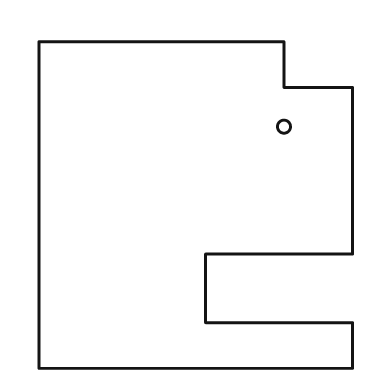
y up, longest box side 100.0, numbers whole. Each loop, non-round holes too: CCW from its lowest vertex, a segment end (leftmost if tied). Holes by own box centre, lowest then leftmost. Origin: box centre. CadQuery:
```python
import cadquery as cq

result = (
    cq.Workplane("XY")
    .moveTo(-48.0, -50.0)
    .lineTo(48.0, -50.0)
    .lineTo(48.0, -36.0)
    .lineTo(3.0, -36.0)
    .lineTo(3.0, -15.0)
    .lineTo(48.0, -15.0)
    .lineTo(48.0, 36.0)
    .lineTo(27.0, 36.0)
    .lineTo(27.0, 50.0)
    .lineTo(-48.0, 50.0)
    .close()
    .moveTo(27.0, 24.0)
    .circle(2.0)
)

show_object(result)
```